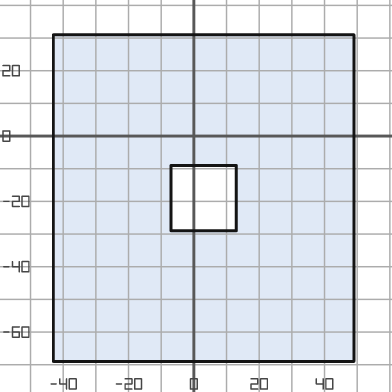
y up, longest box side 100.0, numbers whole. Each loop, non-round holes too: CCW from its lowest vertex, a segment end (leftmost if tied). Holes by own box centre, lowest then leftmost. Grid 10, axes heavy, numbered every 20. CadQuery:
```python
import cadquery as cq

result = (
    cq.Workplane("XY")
    .moveTo(-43.0, -69.0)
    .lineTo(49.0, -69.0)
    .lineTo(49.0, 31.0)
    .lineTo(-43.0, 31.0)
    .close()
    .moveTo(-7.0, -29.0)
    .lineTo(13.0, -29.0)
    .lineTo(13.0, -9.0)
    .lineTo(-7.0, -9.0)
    .close()
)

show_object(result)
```